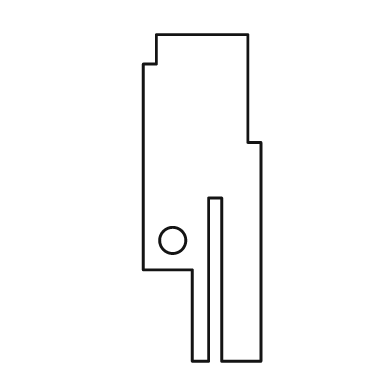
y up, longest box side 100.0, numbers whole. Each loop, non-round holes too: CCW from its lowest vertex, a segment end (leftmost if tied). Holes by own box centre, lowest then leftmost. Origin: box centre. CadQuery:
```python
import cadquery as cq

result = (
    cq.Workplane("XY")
    .moveTo(-3.0, -50.0)
    .lineTo(2.0, -50.0)
    .lineTo(2.0, 0.0)
    .lineTo(6.0, 0.0)
    .lineTo(6.0, -50.0)
    .lineTo(18.0, -50.0)
    .lineTo(18.0, 17.0)
    .lineTo(14.0, 17.0)
    .lineTo(14.0, 50.0)
    .lineTo(-14.0, 50.0)
    .lineTo(-14.0, 41.0)
    .lineTo(-18.0, 41.0)
    .lineTo(-18.0, -22.0)
    .lineTo(-3.0, -22.0)
    .close()
    .moveTo(-9.0, -13.0)
    .circle(4.0)
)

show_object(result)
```